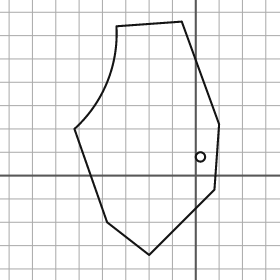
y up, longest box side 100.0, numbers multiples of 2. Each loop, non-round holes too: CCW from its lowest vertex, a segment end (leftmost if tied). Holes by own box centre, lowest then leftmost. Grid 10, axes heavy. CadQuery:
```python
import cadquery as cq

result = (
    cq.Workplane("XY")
    .moveTo(-20.0, -34.0)
    .lineTo(8.0, -6.0)
    .lineTo(10.0, 22.0)
    .lineTo(-6.0, 66.0)
    .lineTo(-34.0, 64.0)
    .threePointArc((-38.0, 40.0), (-52.0, 20.0))
    .lineTo(-38.0, -20.0)
    .close()
    .moveTo(2.0, 8.0)
    .circle(2.0)
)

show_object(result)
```